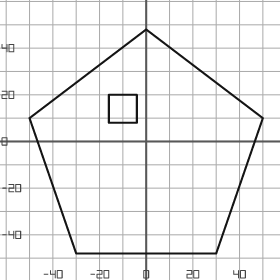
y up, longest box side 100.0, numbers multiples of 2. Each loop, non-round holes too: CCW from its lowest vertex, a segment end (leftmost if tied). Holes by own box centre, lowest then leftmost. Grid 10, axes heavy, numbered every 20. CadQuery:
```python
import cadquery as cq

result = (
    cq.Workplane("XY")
    .moveTo(-30.0, -48.0)
    .lineTo(30.0, -48.0)
    .lineTo(50.0, 10.0)
    .lineTo(0.0, 48.0)
    .lineTo(-50.0, 10.0)
    .close()
    .moveTo(-16.0, 8.0)
    .lineTo(-4.0, 8.0)
    .lineTo(-4.0, 20.0)
    .lineTo(-16.0, 20.0)
    .close()
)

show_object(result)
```